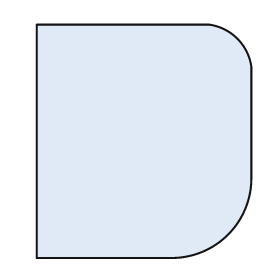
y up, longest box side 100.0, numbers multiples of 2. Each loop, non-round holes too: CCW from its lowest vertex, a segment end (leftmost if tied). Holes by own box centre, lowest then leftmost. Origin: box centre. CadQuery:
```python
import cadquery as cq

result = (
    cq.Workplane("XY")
    .moveTo(-46.0, -50.0)
    .lineTo(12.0, -50.0)
    .threePointArc((36.0, -40.0), (46.0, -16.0))
    .lineTo(46.0, 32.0)
    .threePointArc((40.0, 44.0), (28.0, 50.0))
    .lineTo(-46.0, 50.0)
    .close()
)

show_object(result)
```